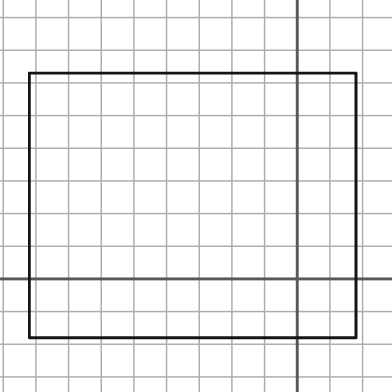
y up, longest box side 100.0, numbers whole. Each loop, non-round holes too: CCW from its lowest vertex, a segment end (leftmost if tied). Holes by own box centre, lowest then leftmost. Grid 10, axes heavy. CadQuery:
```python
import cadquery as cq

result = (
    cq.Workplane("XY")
    .moveTo(-82.0, -18.0)
    .lineTo(18.0, -18.0)
    .lineTo(18.0, 63.0)
    .lineTo(-82.0, 63.0)
    .close()
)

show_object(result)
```